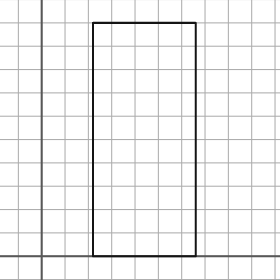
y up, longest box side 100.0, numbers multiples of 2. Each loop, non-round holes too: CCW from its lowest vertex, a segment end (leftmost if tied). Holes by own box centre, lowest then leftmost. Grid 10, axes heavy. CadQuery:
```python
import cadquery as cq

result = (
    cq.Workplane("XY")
    .moveTo(22.0, 0.0)
    .lineTo(66.0, 0.0)
    .lineTo(66.0, 100.0)
    .lineTo(22.0, 100.0)
    .close()
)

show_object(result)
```